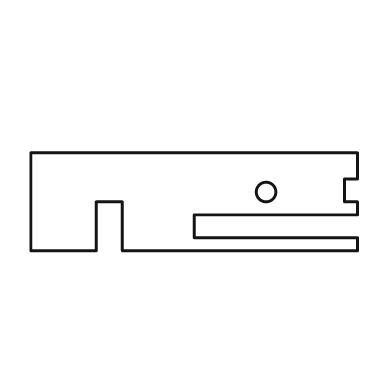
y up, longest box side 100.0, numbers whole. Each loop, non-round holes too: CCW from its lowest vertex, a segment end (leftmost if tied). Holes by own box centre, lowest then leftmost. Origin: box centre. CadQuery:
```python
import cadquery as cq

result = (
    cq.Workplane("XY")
    .moveTo(-50.0, -15.0)
    .lineTo(-30.0, -15.0)
    .lineTo(-30.0, 0.0)
    .lineTo(-22.0, 0.0)
    .lineTo(-22.0, -15.0)
    .lineTo(50.0, -15.0)
    .lineTo(50.0, -11.0)
    .lineTo(0.0, -11.0)
    .lineTo(0.0, -4.0)
    .lineTo(50.0, -4.0)
    .lineTo(50.0, 0.0)
    .lineTo(46.0, 0.0)
    .lineTo(46.0, 7.0)
    .lineTo(50.0, 7.0)
    .lineTo(50.0, 15.0)
    .lineTo(-50.0, 15.0)
    .close()
    .moveTo(22.0, 3.0)
    .circle(3.0)
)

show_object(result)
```